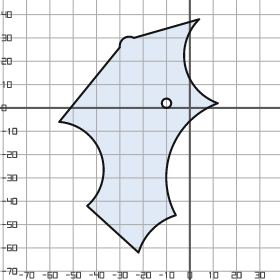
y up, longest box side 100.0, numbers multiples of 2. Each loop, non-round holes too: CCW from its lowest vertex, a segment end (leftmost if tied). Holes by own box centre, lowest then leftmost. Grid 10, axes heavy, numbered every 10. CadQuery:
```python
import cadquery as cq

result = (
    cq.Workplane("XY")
    .moveTo(-22.0, -62.0)
    .threePointArc((-16.0, -52.0), (-6.0, -46.0))
    .threePointArc((-8.0, -18.0), (12.0, 2.0))
    .threePointArc((-2.0, 18.0), (4.0, 38.0))
    .lineTo(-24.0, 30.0)
    .threePointArc((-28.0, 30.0), (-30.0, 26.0))
    .lineTo(-56.0, -6.0)
    .threePointArc((-38.0, -20.0), (-44.0, -42.0))
    .close()
    .moveTo(-10.0, 2.0)
    .circle(2.0)
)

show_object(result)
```